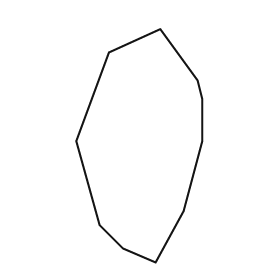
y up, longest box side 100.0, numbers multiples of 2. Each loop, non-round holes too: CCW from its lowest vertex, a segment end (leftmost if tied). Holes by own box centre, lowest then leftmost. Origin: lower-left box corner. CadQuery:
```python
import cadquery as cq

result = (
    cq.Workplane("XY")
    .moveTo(34.0, 0.0)
    .lineTo(46.0, 22.0)
    .lineTo(54.0, 52.0)
    .lineTo(54.0, 70.0)
    .lineTo(52.0, 78.0)
    .lineTo(36.0, 100.0)
    .lineTo(14.0, 90.0)
    .lineTo(0.0, 52.0)
    .lineTo(10.0, 16.0)
    .lineTo(20.0, 6.0)
    .close()
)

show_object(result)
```